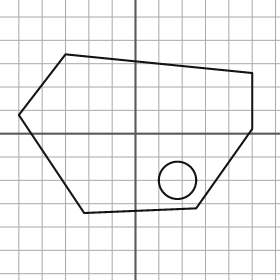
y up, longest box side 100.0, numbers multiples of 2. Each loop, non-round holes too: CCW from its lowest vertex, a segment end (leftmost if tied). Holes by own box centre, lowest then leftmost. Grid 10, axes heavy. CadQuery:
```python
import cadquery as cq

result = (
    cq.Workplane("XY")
    .moveTo(-22.0, -34.0)
    .lineTo(26.0, -32.0)
    .lineTo(50.0, 2.0)
    .lineTo(50.0, 26.0)
    .lineTo(-30.0, 34.0)
    .lineTo(-50.0, 8.0)
    .close()
    .moveTo(18.0, -20.0)
    .circle(8.0)
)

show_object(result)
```